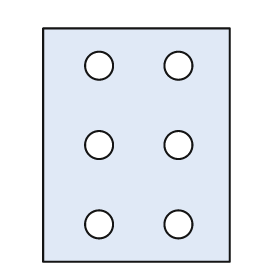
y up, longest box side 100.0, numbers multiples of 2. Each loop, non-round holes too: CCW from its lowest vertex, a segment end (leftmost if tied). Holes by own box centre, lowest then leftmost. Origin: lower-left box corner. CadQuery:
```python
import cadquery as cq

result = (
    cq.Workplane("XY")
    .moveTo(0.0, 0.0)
    .lineTo(80.0, 0.0)
    .lineTo(80.0, 100.0)
    .lineTo(0.0, 100.0)
    .close()
    .moveTo(24.0, 16.0)
    .circle(6.0)
    .moveTo(58.0, 16.0)
    .circle(6.0)
    .moveTo(24.0, 50.0)
    .circle(6.0)
    .moveTo(58.0, 50.0)
    .circle(6.0)
    .moveTo(24.0, 84.0)
    .circle(6.0)
    .moveTo(58.0, 84.0)
    .circle(6.0)
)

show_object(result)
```